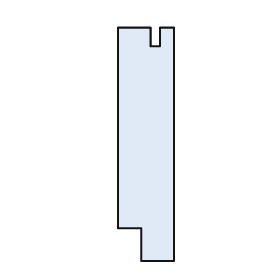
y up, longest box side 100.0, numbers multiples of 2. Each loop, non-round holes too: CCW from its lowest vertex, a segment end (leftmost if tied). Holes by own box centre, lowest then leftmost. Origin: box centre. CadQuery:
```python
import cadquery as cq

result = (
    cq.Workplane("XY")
    .moveTo(-2.0, -50.0)
    .lineTo(12.0, -50.0)
    .lineTo(12.0, 50.0)
    .lineTo(6.0, 50.0)
    .lineTo(6.0, 42.0)
    .lineTo(2.0, 42.0)
    .lineTo(2.0, 50.0)
    .lineTo(-12.0, 50.0)
    .lineTo(-12.0, -36.0)
    .lineTo(-2.0, -36.0)
    .close()
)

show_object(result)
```